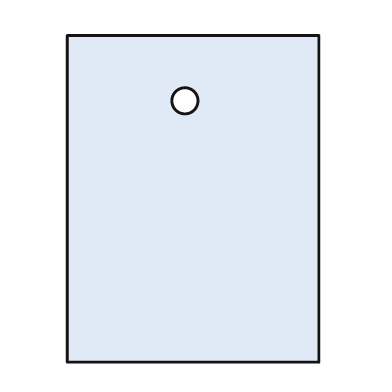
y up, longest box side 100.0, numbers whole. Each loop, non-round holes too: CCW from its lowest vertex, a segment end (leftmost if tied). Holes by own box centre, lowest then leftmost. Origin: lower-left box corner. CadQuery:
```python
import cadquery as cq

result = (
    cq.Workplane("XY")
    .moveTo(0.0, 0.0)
    .lineTo(77.0, 0.0)
    .lineTo(77.0, 100.0)
    .lineTo(0.0, 100.0)
    .close()
    .moveTo(36.0, 80.0)
    .circle(4.0)
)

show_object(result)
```